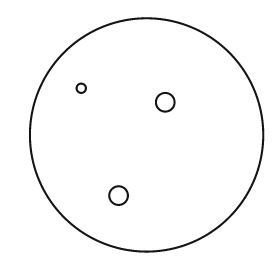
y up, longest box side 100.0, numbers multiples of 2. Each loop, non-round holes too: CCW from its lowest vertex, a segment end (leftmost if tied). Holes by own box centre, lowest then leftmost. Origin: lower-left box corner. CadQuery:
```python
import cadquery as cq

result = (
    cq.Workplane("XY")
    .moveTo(50.0, 50.0)
    .circle(50.0)
    .moveTo(38.0, 24.0)
    .circle(4.0)
    .moveTo(58.0, 64.0)
    .circle(4.0)
    .moveTo(22.0, 70.0)
    .circle(2.0)
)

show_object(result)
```